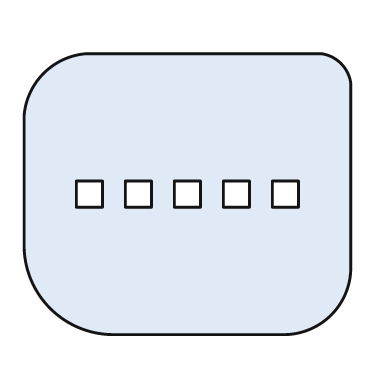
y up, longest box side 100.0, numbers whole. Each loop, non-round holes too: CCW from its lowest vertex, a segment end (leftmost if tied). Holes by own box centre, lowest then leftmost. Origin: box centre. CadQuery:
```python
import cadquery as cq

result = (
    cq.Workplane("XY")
    .moveTo(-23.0, -43.0)
    .lineTo(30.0, -43.0)
    .threePointArc((44.0, -37.0), (50.0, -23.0))
    .lineTo(50.0, 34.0)
    .threePointArc((47.0, 40.0), (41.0, 43.0))
    .lineTo(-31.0, 43.0)
    .threePointArc((-44.0, 37.0), (-50.0, 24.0))
    .lineTo(-50.0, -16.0)
    .threePointArc((-42.0, -35.0), (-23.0, -43.0))
    .close()
    .moveTo(-34.0, -4.0)
    .lineTo(-26.0, -4.0)
    .lineTo(-26.0, 4.0)
    .lineTo(-34.0, 4.0)
    .close()
    .moveTo(-19.0, -4.0)
    .lineTo(-11.0, -4.0)
    .lineTo(-11.0, 4.0)
    .lineTo(-19.0, 4.0)
    .close()
    .moveTo(-4.0, -4.0)
    .lineTo(4.0, -4.0)
    .lineTo(4.0, 4.0)
    .lineTo(-4.0, 4.0)
    .close()
    .moveTo(11.0, -4.0)
    .lineTo(19.0, -4.0)
    .lineTo(19.0, 4.0)
    .lineTo(11.0, 4.0)
    .close()
    .moveTo(26.0, -4.0)
    .lineTo(34.0, -4.0)
    .lineTo(34.0, 4.0)
    .lineTo(26.0, 4.0)
    .close()
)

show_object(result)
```